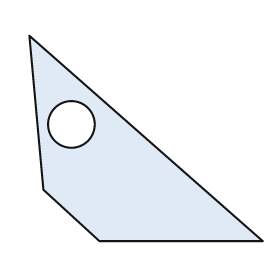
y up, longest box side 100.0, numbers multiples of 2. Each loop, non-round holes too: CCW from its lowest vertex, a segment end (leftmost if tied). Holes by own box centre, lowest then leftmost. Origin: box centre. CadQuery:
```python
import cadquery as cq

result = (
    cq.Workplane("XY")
    .moveTo(-20.0, -44.0)
    .lineTo(50.0, -44.0)
    .lineTo(-50.0, 44.0)
    .lineTo(-44.0, -22.0)
    .close()
    .moveTo(-32.0, 6.0)
    .circle(10.0)
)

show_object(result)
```